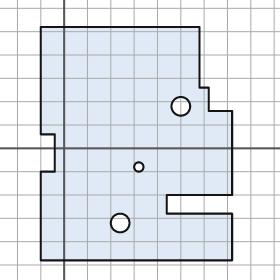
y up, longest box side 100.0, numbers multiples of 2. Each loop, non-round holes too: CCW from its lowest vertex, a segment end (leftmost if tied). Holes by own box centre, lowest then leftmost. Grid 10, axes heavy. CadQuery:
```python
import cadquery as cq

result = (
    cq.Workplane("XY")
    .moveTo(-10.0, -48.0)
    .lineTo(72.0, -48.0)
    .lineTo(72.0, -28.0)
    .lineTo(44.0, -28.0)
    .lineTo(44.0, -20.0)
    .lineTo(72.0, -20.0)
    .lineTo(72.0, 16.0)
    .lineTo(62.0, 16.0)
    .lineTo(62.0, 26.0)
    .lineTo(58.0, 26.0)
    .lineTo(58.0, 52.0)
    .lineTo(-10.0, 52.0)
    .lineTo(-10.0, 6.0)
    .lineTo(-4.0, 6.0)
    .lineTo(-4.0, -10.0)
    .lineTo(-10.0, -10.0)
    .close()
    .moveTo(24.0, -32.0)
    .circle(4.0)
    .moveTo(32.0, -8.0)
    .circle(2.0)
    .moveTo(50.0, 18.0)
    .circle(4.0)
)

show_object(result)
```